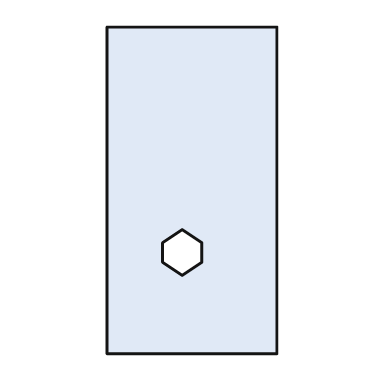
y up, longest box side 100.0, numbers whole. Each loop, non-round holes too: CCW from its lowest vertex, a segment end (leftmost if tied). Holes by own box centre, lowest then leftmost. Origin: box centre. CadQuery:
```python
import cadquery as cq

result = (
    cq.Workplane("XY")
    .moveTo(-26.0, -50.0)
    .lineTo(26.0, -50.0)
    .lineTo(26.0, 50.0)
    .lineTo(-26.0, 50.0)
    .close()
    .moveTo(-3.0, -26.0)
    .lineTo(3.0, -22.0)
    .lineTo(3.0, -16.0)
    .lineTo(-3.0, -12.0)
    .lineTo(-9.0, -16.0)
    .lineTo(-9.0, -22.0)
    .close()
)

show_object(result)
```